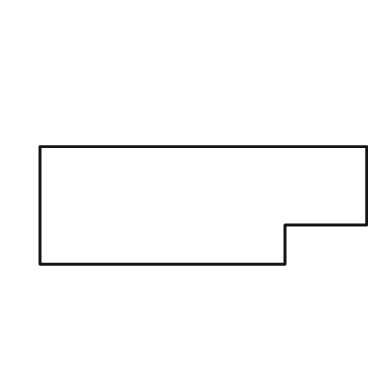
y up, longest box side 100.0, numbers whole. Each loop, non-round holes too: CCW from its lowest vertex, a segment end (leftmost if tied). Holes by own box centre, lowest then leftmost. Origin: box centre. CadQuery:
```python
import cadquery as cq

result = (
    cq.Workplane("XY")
    .moveTo(-50.0, -18.0)
    .lineTo(25.0, -18.0)
    .lineTo(25.0, -6.0)
    .lineTo(50.0, -6.0)
    .lineTo(50.0, 18.0)
    .lineTo(-50.0, 18.0)
    .close()
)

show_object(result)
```